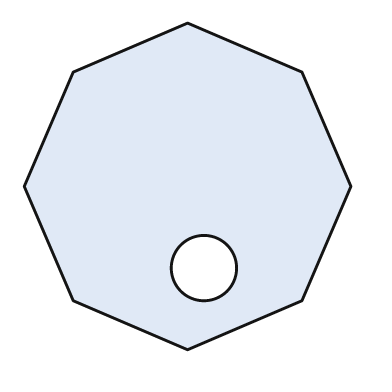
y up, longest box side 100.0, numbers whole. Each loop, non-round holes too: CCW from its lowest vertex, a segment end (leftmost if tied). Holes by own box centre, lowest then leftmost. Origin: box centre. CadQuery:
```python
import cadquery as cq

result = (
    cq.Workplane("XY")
    .moveTo(0.0, -50.0)
    .lineTo(35.0, -35.0)
    .lineTo(50.0, 0.0)
    .lineTo(35.0, 35.0)
    .lineTo(0.0, 50.0)
    .lineTo(-35.0, 35.0)
    .lineTo(-50.0, 0.0)
    .lineTo(-35.0, -35.0)
    .close()
    .moveTo(5.0, -25.0)
    .circle(10.0)
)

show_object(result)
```